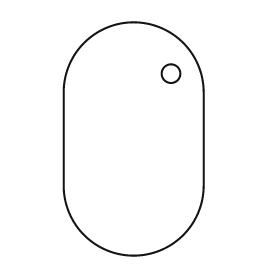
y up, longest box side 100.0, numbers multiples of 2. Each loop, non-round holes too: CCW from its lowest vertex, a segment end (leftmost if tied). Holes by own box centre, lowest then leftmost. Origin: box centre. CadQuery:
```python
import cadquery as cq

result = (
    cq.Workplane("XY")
    .moveTo(-30.0, -20.0)
    .threePointArc((0.0, -50.0), (30.0, -20.0))
    .lineTo(30.0, 20.0)
    .threePointArc((0.0, 50.0), (-30.0, 20.0))
    .close()
    .moveTo(16.0, 28.0)
    .circle(4.0)
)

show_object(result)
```